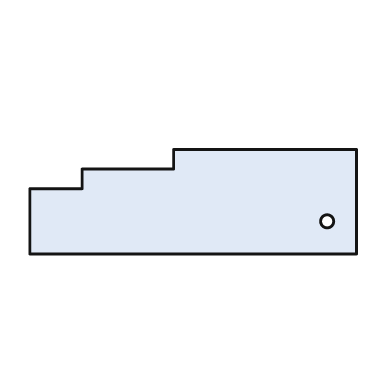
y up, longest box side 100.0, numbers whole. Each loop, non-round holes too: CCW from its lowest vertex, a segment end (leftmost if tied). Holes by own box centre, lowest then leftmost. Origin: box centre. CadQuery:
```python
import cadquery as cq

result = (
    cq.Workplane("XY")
    .moveTo(-50.0, -16.0)
    .lineTo(50.0, -16.0)
    .lineTo(50.0, 16.0)
    .lineTo(-6.0, 16.0)
    .lineTo(-6.0, 10.0)
    .lineTo(-34.0, 10.0)
    .lineTo(-34.0, 4.0)
    .lineTo(-50.0, 4.0)
    .close()
    .moveTo(41.0, -6.0)
    .circle(2.0)
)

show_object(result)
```